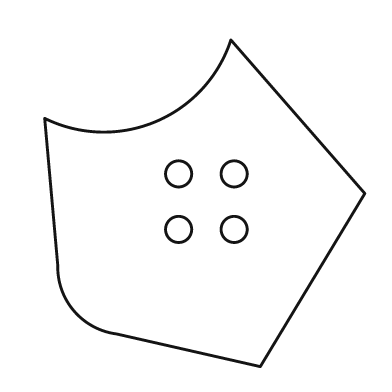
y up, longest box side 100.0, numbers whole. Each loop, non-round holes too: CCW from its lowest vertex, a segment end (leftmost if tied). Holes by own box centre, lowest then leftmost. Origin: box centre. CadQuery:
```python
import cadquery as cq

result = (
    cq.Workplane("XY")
    .moveTo(17.0, -50.0)
    .lineTo(49.0, 3.0)
    .lineTo(8.0, 50.0)
    .threePointArc((-15.0, 25.0), (-49.0, 26.0))
    .lineTo(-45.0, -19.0)
    .threePointArc((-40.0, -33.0), (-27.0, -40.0))
    .close()
    .moveTo(-8.0, -8.0)
    .circle(4.0)
    .moveTo(9.0, -8.0)
    .circle(4.0)
    .moveTo(-8.0, 9.0)
    .circle(4.0)
    .moveTo(9.0, 9.0)
    .circle(4.0)
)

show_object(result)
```